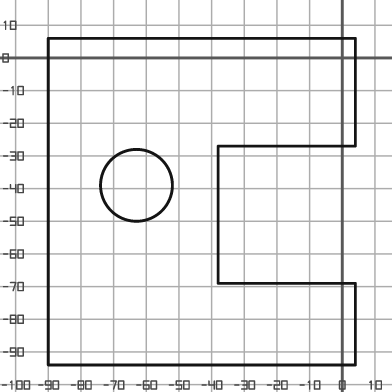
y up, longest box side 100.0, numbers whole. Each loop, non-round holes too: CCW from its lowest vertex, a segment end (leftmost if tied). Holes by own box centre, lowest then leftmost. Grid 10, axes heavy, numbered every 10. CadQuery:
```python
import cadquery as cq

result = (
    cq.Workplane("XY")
    .moveTo(-90.0, -94.0)
    .lineTo(4.0, -94.0)
    .lineTo(4.0, -69.0)
    .lineTo(-38.0, -69.0)
    .lineTo(-38.0, -27.0)
    .lineTo(4.0, -27.0)
    .lineTo(4.0, 6.0)
    .lineTo(-90.0, 6.0)
    .close()
    .moveTo(-63.0, -39.0)
    .circle(11.0)
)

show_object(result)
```